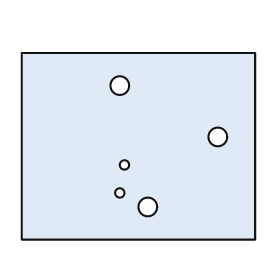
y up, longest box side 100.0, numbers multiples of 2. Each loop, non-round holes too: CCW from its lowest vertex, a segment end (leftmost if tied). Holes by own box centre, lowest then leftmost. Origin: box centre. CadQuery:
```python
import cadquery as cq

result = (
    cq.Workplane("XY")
    .moveTo(-50.0, -40.0)
    .lineTo(50.0, -40.0)
    .lineTo(50.0, 40.0)
    .lineTo(-50.0, 40.0)
    .close()
    .moveTo(4.0, -26.0)
    .circle(4.0)
    .moveTo(-8.0, -20.0)
    .circle(2.0)
    .moveTo(-6.0, -8.0)
    .circle(2.0)
    .moveTo(34.0, 4.0)
    .circle(4.0)
    .moveTo(-8.0, 26.0)
    .circle(4.0)
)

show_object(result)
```